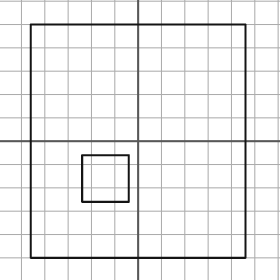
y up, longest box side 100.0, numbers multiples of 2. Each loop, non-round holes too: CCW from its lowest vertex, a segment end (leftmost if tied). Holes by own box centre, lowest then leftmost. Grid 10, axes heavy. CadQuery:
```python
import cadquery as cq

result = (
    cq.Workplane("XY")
    .moveTo(-46.0, -50.0)
    .lineTo(46.0, -50.0)
    .lineTo(46.0, 50.0)
    .lineTo(-46.0, 50.0)
    .close()
    .moveTo(-24.0, -26.0)
    .lineTo(-4.0, -26.0)
    .lineTo(-4.0, -6.0)
    .lineTo(-24.0, -6.0)
    .close()
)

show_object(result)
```